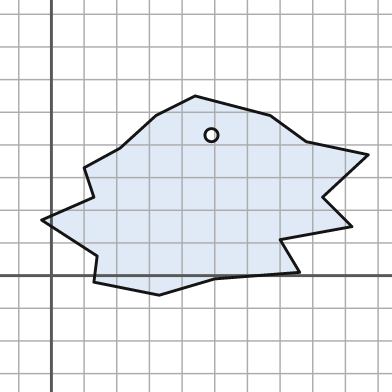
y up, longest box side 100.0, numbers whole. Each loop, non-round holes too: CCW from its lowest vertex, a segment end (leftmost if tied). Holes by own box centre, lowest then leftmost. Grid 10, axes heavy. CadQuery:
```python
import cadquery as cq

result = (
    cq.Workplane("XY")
    .moveTo(33.0, -6.0)
    .lineTo(50.0, -1.0)
    .lineTo(76.0, 1.0)
    .lineTo(70.0, 11.0)
    .lineTo(92.0, 15.0)
    .lineTo(83.0, 24.0)
    .lineTo(97.0, 37.0)
    .lineTo(78.0, 41.0)
    .lineTo(67.0, 49.0)
    .lineTo(44.0, 55.0)
    .lineTo(32.0, 49.0)
    .lineTo(21.0, 39.0)
    .lineTo(10.0, 33.0)
    .lineTo(13.0, 24.0)
    .lineTo(-3.0, 17.0)
    .lineTo(14.0, 6.0)
    .lineTo(13.0, -2.0)
    .close()
    .moveTo(49.0, 43.0)
    .circle(2.0)
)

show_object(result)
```